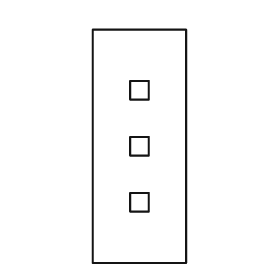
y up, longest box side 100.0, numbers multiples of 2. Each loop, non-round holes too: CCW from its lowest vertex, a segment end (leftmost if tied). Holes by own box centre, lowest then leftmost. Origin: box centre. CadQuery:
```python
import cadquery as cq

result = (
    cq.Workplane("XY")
    .moveTo(-20.0, -50.0)
    .lineTo(20.0, -50.0)
    .lineTo(20.0, 50.0)
    .lineTo(-20.0, 50.0)
    .close()
    .moveTo(-4.0, -28.0)
    .lineTo(4.0, -28.0)
    .lineTo(4.0, -20.0)
    .lineTo(-4.0, -20.0)
    .close()
    .moveTo(-4.0, -4.0)
    .lineTo(4.0, -4.0)
    .lineTo(4.0, 4.0)
    .lineTo(-4.0, 4.0)
    .close()
    .moveTo(-4.0, 20.0)
    .lineTo(4.0, 20.0)
    .lineTo(4.0, 28.0)
    .lineTo(-4.0, 28.0)
    .close()
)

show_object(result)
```